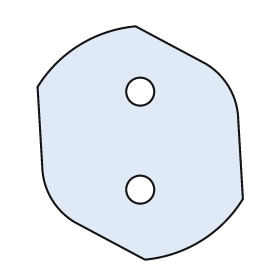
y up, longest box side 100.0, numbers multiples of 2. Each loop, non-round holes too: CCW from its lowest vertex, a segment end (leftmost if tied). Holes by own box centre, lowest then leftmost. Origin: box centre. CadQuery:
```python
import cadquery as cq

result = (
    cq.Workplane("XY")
    .moveTo(2.0, -50.0)
    .threePointArc((26.0, -42.0), (44.0, -24.0))
    .lineTo(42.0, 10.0)
    .threePointArc((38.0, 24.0), (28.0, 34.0))
    .lineTo(-2.0, 50.0)
    .threePointArc((-26.0, 42.0), (-44.0, 24.0))
    .lineTo(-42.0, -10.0)
    .threePointArc((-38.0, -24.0), (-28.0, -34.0))
    .close()
    .moveTo(0.0, -20.0)
    .circle(6.0)
    .moveTo(0.0, 22.0)
    .circle(6.0)
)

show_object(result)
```